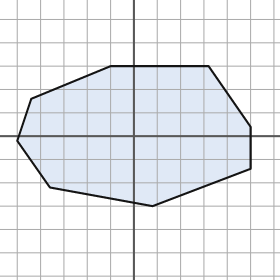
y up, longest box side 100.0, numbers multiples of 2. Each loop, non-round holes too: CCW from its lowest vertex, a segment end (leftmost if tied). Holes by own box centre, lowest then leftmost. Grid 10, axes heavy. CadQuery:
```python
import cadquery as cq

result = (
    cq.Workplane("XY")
    .moveTo(8.0, -30.0)
    .lineTo(50.0, -14.0)
    .lineTo(50.0, 4.0)
    .lineTo(32.0, 30.0)
    .lineTo(-10.0, 30.0)
    .lineTo(-44.0, 16.0)
    .lineTo(-50.0, -2.0)
    .lineTo(-36.0, -22.0)
    .close()
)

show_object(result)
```